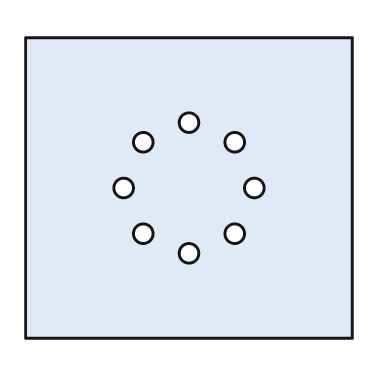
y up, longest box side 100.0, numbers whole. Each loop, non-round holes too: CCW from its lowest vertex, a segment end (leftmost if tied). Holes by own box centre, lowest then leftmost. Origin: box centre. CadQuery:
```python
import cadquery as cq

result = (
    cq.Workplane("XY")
    .moveTo(-50.0, -46.0)
    .lineTo(50.0, -46.0)
    .lineTo(50.0, 46.0)
    .lineTo(-50.0, 46.0)
    .close()
    .moveTo(0.0, -20.0)
    .circle(3.0)
    .moveTo(-14.0, -14.0)
    .circle(3.0)
    .moveTo(14.0, -14.0)
    .circle(3.0)
    .moveTo(-20.0, 0.0)
    .circle(3.0)
    .moveTo(20.0, 0.0)
    .circle(3.0)
    .moveTo(-14.0, 14.0)
    .circle(3.0)
    .moveTo(14.0, 14.0)
    .circle(3.0)
    .moveTo(0.0, 20.0)
    .circle(3.0)
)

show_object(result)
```